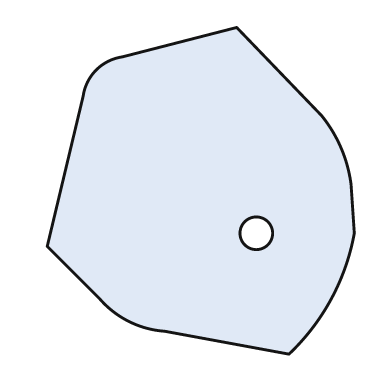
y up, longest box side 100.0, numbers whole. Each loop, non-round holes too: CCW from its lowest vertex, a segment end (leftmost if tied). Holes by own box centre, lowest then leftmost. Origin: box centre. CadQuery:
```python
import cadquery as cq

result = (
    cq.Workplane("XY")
    .moveTo(27.0, -50.0)
    .threePointArc((40.0, -33.0), (47.0, -13.0))
    .lineTo(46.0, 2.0)
    .threePointArc((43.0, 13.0), (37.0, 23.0))
    .lineTo(11.0, 50.0)
    .lineTo(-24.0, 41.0)
    .threePointArc((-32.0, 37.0), (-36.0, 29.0))
    .lineTo(-47.0, -17.0)
    .lineTo(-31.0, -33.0)
    .threePointArc((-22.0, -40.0), (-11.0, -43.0))
    .close()
    .moveTo(17.0, -13.0)
    .circle(5.0)
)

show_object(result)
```